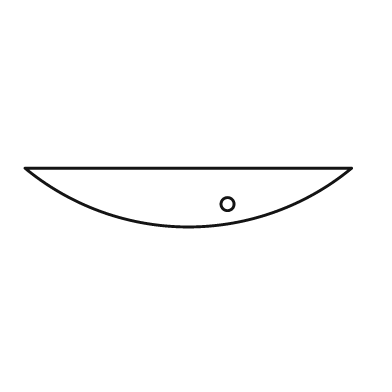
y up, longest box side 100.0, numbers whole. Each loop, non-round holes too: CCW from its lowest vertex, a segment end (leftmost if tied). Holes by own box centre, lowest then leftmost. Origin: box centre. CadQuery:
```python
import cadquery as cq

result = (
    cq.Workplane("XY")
    .moveTo(-50.0, 9.0)
    .threePointArc((0.0, -9.0), (50.0, 9.0))
    .close()
    .moveTo(12.0, -2.0)
    .circle(2.0)
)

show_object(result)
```